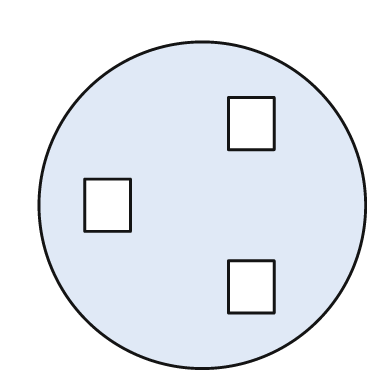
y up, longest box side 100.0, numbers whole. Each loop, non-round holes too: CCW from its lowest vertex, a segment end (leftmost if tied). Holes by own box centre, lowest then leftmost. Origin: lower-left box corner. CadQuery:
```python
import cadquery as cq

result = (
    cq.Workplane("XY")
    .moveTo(50.0, 50.0)
    .circle(50.0)
    .moveTo(58.0, 17.0)
    .lineTo(72.0, 17.0)
    .lineTo(72.0, 33.0)
    .lineTo(58.0, 33.0)
    .close()
    .moveTo(14.0, 42.0)
    .lineTo(28.0, 42.0)
    .lineTo(28.0, 58.0)
    .lineTo(14.0, 58.0)
    .close()
    .moveTo(58.0, 67.0)
    .lineTo(72.0, 67.0)
    .lineTo(72.0, 83.0)
    .lineTo(58.0, 83.0)
    .close()
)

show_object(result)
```